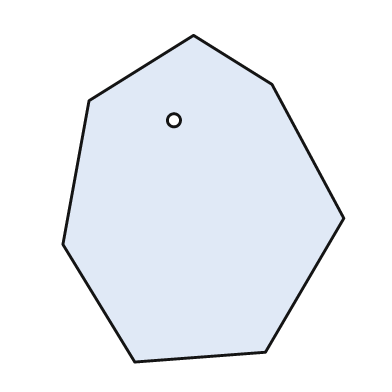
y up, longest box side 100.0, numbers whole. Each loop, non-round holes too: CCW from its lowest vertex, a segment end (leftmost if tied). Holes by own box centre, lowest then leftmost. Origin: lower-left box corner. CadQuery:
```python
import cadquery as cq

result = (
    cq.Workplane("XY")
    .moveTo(22.0, 0.0)
    .lineTo(62.0, 3.0)
    .lineTo(86.0, 44.0)
    .lineTo(64.0, 85.0)
    .lineTo(40.0, 100.0)
    .lineTo(8.0, 80.0)
    .lineTo(0.0, 36.0)
    .close()
    .moveTo(34.0, 74.0)
    .circle(2.0)
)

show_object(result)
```